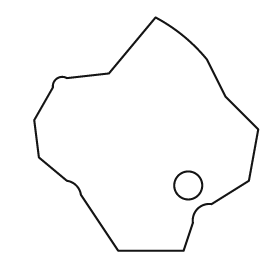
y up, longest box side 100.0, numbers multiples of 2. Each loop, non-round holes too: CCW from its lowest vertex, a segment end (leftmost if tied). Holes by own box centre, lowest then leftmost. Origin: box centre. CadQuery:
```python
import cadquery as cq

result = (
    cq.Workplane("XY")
    .moveTo(-12.0, -50.0)
    .lineTo(16.0, -50.0)
    .lineTo(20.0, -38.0)
    .threePointArc((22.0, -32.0), (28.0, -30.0))
    .lineTo(44.0, -20.0)
    .lineTo(48.0, 2.0)
    .lineTo(34.0, 16.0)
    .lineTo(26.0, 32.0)
    .threePointArc((16.0, 42.0), (4.0, 50.0))
    .lineTo(-16.0, 26.0)
    .lineTo(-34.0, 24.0)
    .threePointArc((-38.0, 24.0), (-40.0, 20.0))
    .lineTo(-48.0, 6.0)
    .lineTo(-46.0, -10.0)
    .lineTo(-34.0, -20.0)
    .threePointArc((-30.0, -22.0), (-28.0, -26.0))
    .close()
    .moveTo(18.0, -22.0)
    .circle(6.0)
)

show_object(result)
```